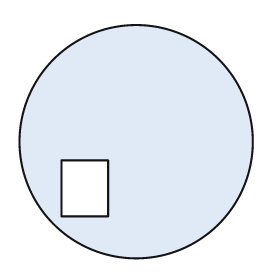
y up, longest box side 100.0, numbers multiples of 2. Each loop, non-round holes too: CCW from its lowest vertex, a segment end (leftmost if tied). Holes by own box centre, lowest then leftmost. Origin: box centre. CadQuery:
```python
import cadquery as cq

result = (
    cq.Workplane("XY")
    .moveTo(0.0, 0.0)
    .circle(50.0)
    .moveTo(-32.0, -32.0)
    .lineTo(-12.0, -32.0)
    .lineTo(-12.0, -8.0)
    .lineTo(-32.0, -8.0)
    .close()
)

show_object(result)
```